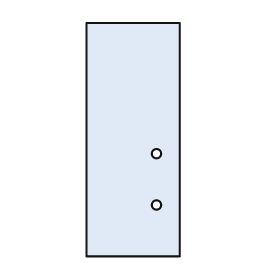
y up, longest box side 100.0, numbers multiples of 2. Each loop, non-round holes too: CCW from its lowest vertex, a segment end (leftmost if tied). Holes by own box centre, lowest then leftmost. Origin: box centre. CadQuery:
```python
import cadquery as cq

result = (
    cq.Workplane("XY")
    .moveTo(-20.0, -50.0)
    .lineTo(20.0, -50.0)
    .lineTo(20.0, 50.0)
    .lineTo(-20.0, 50.0)
    .close()
    .moveTo(10.0, -28.0)
    .circle(2.0)
    .moveTo(10.0, -6.0)
    .circle(2.0)
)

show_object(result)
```